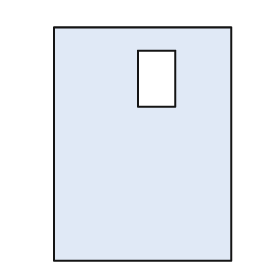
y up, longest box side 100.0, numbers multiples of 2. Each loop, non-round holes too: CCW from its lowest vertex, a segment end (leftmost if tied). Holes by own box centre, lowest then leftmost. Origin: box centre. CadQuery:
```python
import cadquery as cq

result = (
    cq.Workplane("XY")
    .moveTo(-38.0, -50.0)
    .lineTo(38.0, -50.0)
    .lineTo(38.0, 50.0)
    .lineTo(-38.0, 50.0)
    .close()
    .moveTo(-2.0, 16.0)
    .lineTo(14.0, 16.0)
    .lineTo(14.0, 40.0)
    .lineTo(-2.0, 40.0)
    .close()
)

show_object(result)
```